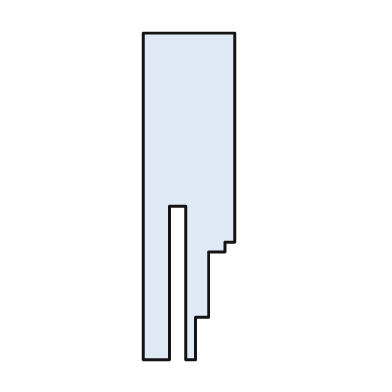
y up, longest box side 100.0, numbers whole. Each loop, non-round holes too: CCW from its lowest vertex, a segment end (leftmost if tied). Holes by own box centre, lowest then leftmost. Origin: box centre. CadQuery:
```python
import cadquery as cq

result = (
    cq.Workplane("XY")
    .moveTo(-14.0, -50.0)
    .lineTo(-6.0, -50.0)
    .lineTo(-6.0, -3.0)
    .lineTo(-1.0, -3.0)
    .lineTo(-1.0, -50.0)
    .lineTo(2.0, -50.0)
    .lineTo(2.0, -37.0)
    .lineTo(6.0, -37.0)
    .lineTo(6.0, -17.0)
    .lineTo(11.0, -17.0)
    .lineTo(11.0, -14.0)
    .lineTo(14.0, -14.0)
    .lineTo(14.0, 50.0)
    .lineTo(-14.0, 50.0)
    .close()
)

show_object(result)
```